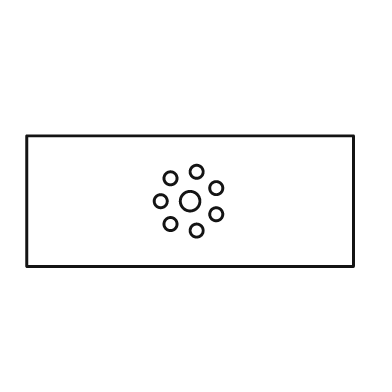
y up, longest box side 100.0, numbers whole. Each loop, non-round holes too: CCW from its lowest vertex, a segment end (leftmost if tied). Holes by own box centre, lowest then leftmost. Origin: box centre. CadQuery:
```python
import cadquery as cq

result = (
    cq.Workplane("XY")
    .moveTo(-50.0, -20.0)
    .lineTo(50.0, -20.0)
    .lineTo(50.0, 20.0)
    .lineTo(-50.0, 20.0)
    .close()
    .moveTo(2.0, -9.0)
    .circle(2.0)
    .moveTo(-6.0, -7.0)
    .circle(2.0)
    .moveTo(8.0, -4.0)
    .circle(2.0)
    .moveTo(-9.0, 0.0)
    .circle(2.0)
    .moveTo(0.0, 0.0)
    .circle(3.0)
    .moveTo(8.0, 4.0)
    .circle(2.0)
    .moveTo(-6.0, 7.0)
    .circle(2.0)
    .moveTo(2.0, 9.0)
    .circle(2.0)
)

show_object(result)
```